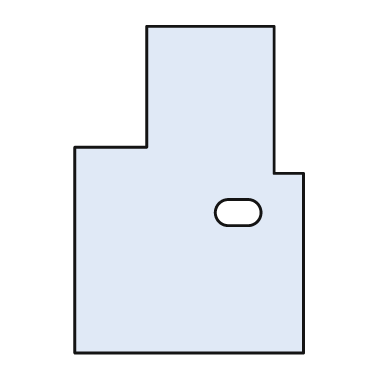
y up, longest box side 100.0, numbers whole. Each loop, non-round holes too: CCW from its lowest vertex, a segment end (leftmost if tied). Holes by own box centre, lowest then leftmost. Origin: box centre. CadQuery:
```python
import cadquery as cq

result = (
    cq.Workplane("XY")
    .moveTo(-35.0, -50.0)
    .lineTo(35.0, -50.0)
    .lineTo(35.0, 5.0)
    .lineTo(26.0, 5.0)
    .lineTo(26.0, 50.0)
    .lineTo(-13.0, 50.0)
    .lineTo(-13.0, 13.0)
    .lineTo(-35.0, 13.0)
    .close()
    .moveTo(12.0, -11.0)
    .lineTo(18.0, -11.0)
    .threePointArc((22.0, -7.0), (18.0, -3.0))
    .lineTo(12.0, -3.0)
    .threePointArc((8.0, -7.0), (12.0, -11.0))
    .close()
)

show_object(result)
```